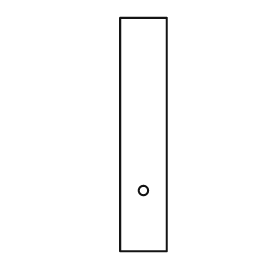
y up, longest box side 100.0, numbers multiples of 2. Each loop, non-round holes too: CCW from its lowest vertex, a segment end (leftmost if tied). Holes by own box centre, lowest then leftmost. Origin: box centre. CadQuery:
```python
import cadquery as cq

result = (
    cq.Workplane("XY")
    .moveTo(-10.0, -50.0)
    .lineTo(10.0, -50.0)
    .lineTo(10.0, 50.0)
    .lineTo(-10.0, 50.0)
    .close()
    .moveTo(0.0, -24.0)
    .circle(2.0)
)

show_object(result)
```